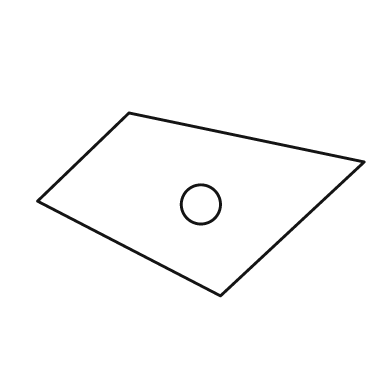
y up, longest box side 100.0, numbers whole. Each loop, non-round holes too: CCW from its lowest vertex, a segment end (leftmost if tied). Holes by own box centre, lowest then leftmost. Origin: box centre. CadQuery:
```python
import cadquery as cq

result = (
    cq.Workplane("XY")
    .moveTo(6.0, -28.0)
    .lineTo(50.0, 13.0)
    .lineTo(-22.0, 28.0)
    .lineTo(-50.0, 1.0)
    .close()
    .moveTo(0.0, 0.0)
    .circle(6.0)
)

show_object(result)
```